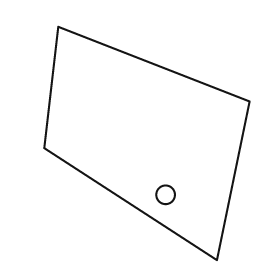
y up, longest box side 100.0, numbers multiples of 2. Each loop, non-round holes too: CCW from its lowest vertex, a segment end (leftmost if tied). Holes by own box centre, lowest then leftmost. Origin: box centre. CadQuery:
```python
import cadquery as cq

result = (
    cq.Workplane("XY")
    .moveTo(30.0, -50.0)
    .lineTo(44.0, 18.0)
    .lineTo(-38.0, 50.0)
    .lineTo(-44.0, -2.0)
    .close()
    .moveTo(8.0, -22.0)
    .circle(4.0)
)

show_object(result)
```